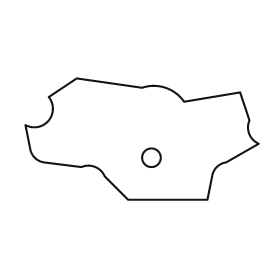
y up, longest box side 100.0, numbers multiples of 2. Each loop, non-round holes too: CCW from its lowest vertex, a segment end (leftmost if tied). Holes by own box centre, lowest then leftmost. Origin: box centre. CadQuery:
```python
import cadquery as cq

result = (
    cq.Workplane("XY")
    .moveTo(-6.0, -26.0)
    .lineTo(28.0, -26.0)
    .lineTo(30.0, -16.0)
    .threePointArc((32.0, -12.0), (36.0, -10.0))
    .lineTo(50.0, -2.0)
    .threePointArc((46.0, 2.0), (46.0, 8.0))
    .lineTo(42.0, 20.0)
    .lineTo(18.0, 16.0)
    .threePointArc((10.0, 22.0), (0.0, 22.0))
    .lineTo(-28.0, 26.0)
    .lineTo(-40.0, 18.0)
    .threePointArc((-40.0, 8.0), (-50.0, 6.0))
    .lineTo(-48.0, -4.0)
    .threePointArc((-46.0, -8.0), (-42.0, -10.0))
    .lineTo(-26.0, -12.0)
    .threePointArc((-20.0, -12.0), (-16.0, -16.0))
    .close()
    .moveTo(4.0, -8.0)
    .circle(4.0)
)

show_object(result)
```